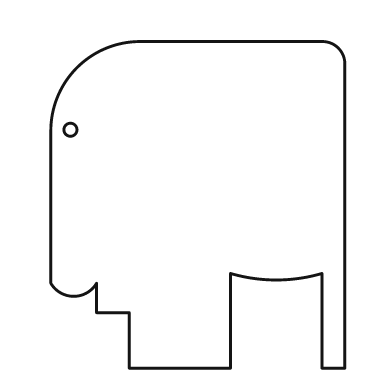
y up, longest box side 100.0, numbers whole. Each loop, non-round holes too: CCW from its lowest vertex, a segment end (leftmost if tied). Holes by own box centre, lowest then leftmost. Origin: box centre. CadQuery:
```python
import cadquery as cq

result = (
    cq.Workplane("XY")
    .moveTo(-21.0, -50.0)
    .lineTo(10.0, -50.0)
    .lineTo(10.0, -21.0)
    .threePointArc((24.0, -23.0), (38.0, -21.0))
    .lineTo(38.0, -50.0)
    .lineTo(45.0, -50.0)
    .lineTo(45.0, 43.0)
    .threePointArc((43.0, 48.0), (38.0, 50.0))
    .lineTo(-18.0, 50.0)
    .threePointArc((-37.0, 42.0), (-45.0, 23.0))
    .lineTo(-45.0, -24.0)
    .threePointArc((-38.0, -28.0), (-31.0, -24.0))
    .lineTo(-31.0, -33.0)
    .lineTo(-21.0, -33.0)
    .close()
    .moveTo(-39.0, 23.0)
    .circle(2.0)
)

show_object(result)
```